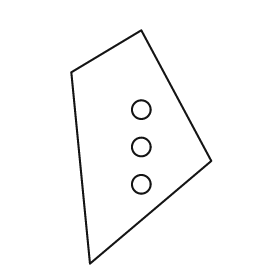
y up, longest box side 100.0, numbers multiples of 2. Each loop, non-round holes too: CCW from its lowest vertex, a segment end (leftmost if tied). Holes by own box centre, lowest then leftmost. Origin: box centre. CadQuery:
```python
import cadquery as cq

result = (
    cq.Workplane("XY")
    .moveTo(-22.0, -50.0)
    .lineTo(30.0, -6.0)
    .lineTo(0.0, 50.0)
    .lineTo(-30.0, 32.0)
    .close()
    .moveTo(0.0, -16.0)
    .circle(4.0)
    .moveTo(0.0, 0.0)
    .circle(4.0)
    .moveTo(0.0, 16.0)
    .circle(4.0)
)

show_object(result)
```